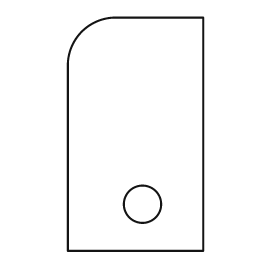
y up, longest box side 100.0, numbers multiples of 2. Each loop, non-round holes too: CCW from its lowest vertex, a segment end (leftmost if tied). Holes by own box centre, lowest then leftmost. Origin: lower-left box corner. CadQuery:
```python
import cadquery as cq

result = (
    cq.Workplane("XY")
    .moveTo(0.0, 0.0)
    .lineTo(58.0, 0.0)
    .lineTo(58.0, 100.0)
    .lineTo(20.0, 100.0)
    .threePointArc((6.0, 94.0), (0.0, 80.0))
    .close()
    .moveTo(32.0, 20.0)
    .circle(8.0)
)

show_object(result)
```